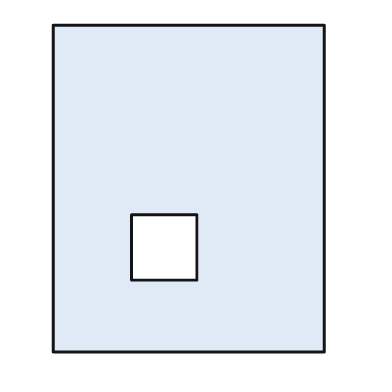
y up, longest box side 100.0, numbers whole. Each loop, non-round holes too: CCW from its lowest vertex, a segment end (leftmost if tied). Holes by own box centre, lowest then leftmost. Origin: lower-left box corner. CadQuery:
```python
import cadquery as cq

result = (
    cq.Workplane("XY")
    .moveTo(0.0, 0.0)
    .lineTo(83.0, 0.0)
    .lineTo(83.0, 100.0)
    .lineTo(0.0, 100.0)
    .close()
    .moveTo(24.0, 22.0)
    .lineTo(44.0, 22.0)
    .lineTo(44.0, 42.0)
    .lineTo(24.0, 42.0)
    .close()
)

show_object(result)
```